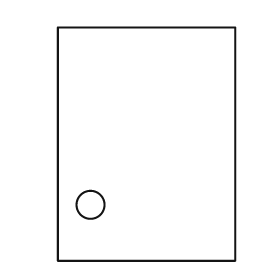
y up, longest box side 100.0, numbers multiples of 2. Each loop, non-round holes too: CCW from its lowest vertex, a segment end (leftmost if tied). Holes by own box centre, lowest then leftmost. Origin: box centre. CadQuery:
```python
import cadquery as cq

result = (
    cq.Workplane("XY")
    .moveTo(-38.0, -50.0)
    .lineTo(38.0, -50.0)
    .lineTo(38.0, 50.0)
    .lineTo(-38.0, 50.0)
    .close()
    .moveTo(-24.0, -26.0)
    .circle(6.0)
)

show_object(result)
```